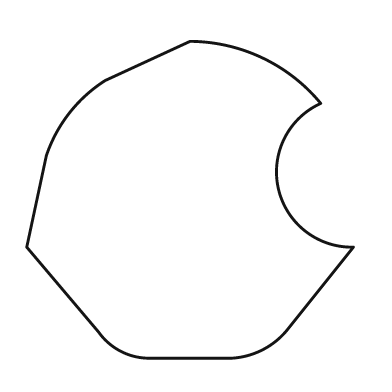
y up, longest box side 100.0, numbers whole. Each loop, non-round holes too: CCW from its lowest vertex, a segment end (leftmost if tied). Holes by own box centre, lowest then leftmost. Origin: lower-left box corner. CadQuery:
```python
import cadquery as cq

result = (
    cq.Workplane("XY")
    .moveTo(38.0, 0.0)
    .lineTo(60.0, 0.0)
    .threePointArc((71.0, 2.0), (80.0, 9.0))
    .lineTo(100.0, 34.0)
    .threePointArc((77.0, 52.0), (90.0, 78.0))
    .threePointArc((72.0, 92.0), (50.0, 97.0))
    .lineTo(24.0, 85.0)
    .threePointArc((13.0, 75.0), (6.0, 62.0))
    .lineTo(0.0, 34.0)
    .lineTo(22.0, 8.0)
    .threePointArc((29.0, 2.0), (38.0, 0.0))
    .close()
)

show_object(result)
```